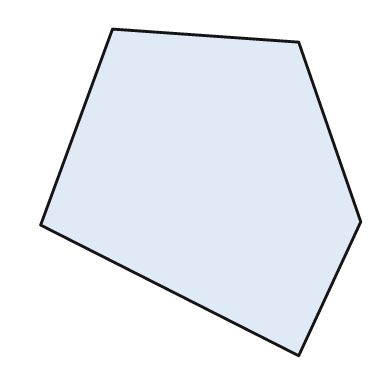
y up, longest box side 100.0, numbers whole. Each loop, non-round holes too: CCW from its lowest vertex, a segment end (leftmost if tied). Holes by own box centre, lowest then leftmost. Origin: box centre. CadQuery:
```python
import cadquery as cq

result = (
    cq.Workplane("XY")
    .moveTo(30.0, -50.0)
    .lineTo(49.0, -9.0)
    .lineTo(30.0, 46.0)
    .lineTo(-27.0, 50.0)
    .lineTo(-49.0, -10.0)
    .close()
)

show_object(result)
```